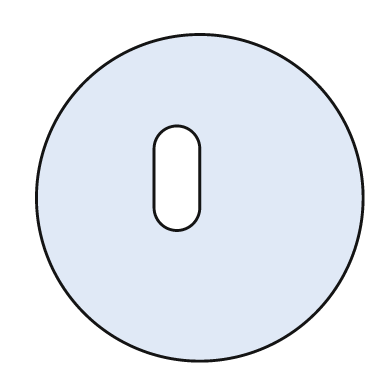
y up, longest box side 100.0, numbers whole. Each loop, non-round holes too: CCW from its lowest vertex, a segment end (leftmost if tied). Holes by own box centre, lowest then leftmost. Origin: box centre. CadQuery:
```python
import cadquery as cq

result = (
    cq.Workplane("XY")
    .moveTo(0.0, 0.0)
    .circle(50.0)
    .moveTo(-14.0, -3.0)
    .threePointArc((-7.0, -10.0), (0.0, -3.0))
    .lineTo(0.0, 15.0)
    .threePointArc((-7.0, 22.0), (-14.0, 15.0))
    .close()
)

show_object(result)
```